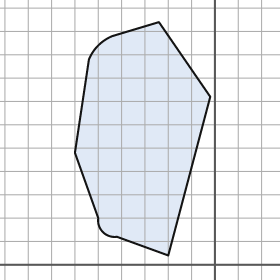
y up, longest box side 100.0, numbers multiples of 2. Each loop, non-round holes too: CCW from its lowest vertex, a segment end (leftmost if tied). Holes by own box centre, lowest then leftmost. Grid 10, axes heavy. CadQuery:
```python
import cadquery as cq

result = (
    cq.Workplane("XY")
    .moveTo(-20.0, 4.0)
    .lineTo(-2.0, 72.0)
    .lineTo(-24.0, 104.0)
    .lineTo(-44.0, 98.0)
    .threePointArc((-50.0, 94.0), (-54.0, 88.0))
    .lineTo(-60.0, 48.0)
    .lineTo(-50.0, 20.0)
    .threePointArc((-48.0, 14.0), (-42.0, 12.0))
    .close()
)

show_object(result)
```